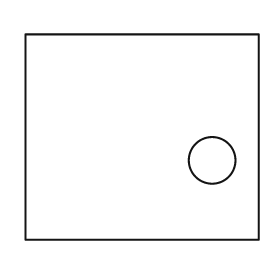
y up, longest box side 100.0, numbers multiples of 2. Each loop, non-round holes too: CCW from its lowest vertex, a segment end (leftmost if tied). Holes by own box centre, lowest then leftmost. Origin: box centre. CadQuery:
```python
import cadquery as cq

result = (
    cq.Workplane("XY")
    .moveTo(-50.0, -44.0)
    .lineTo(50.0, -44.0)
    .lineTo(50.0, 44.0)
    .lineTo(-50.0, 44.0)
    .close()
    .moveTo(30.0, -10.0)
    .circle(10.0)
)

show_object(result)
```